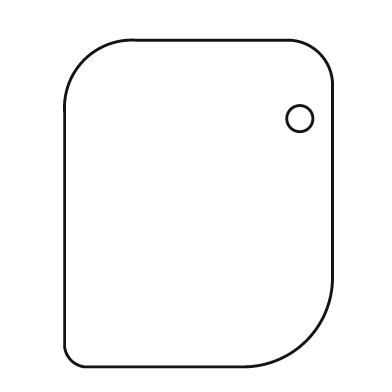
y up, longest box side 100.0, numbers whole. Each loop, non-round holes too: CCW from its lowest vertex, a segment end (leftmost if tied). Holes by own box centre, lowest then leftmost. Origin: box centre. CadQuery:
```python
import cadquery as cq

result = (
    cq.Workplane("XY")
    .moveTo(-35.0, -50.0)
    .lineTo(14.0, -50.0)
    .threePointArc((33.0, -42.0), (41.0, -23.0))
    .lineTo(41.0, 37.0)
    .threePointArc((37.0, 46.0), (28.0, 50.0))
    .lineTo(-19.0, 50.0)
    .threePointArc((-35.0, 44.0), (-41.0, 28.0))
    .lineTo(-41.0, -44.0)
    .threePointArc((-39.0, -48.0), (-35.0, -50.0))
    .close()
    .moveTo(31.0, 26.0)
    .circle(4.0)
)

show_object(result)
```